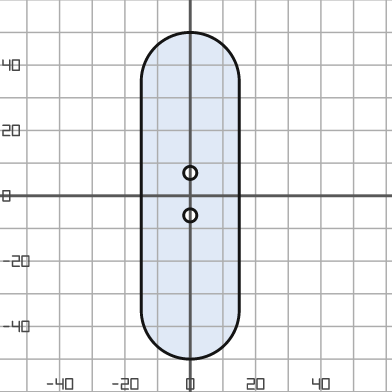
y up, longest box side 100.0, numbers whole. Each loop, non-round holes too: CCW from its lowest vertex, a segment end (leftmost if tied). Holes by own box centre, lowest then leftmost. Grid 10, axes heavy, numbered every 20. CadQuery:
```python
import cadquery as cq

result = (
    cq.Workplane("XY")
    .moveTo(-15.0, -35.0)
    .threePointArc((0.0, -50.0), (15.0, -35.0))
    .lineTo(15.0, 35.0)
    .threePointArc((0.0, 50.0), (-15.0, 35.0))
    .close()
    .moveTo(0.0, -6.0)
    .circle(2.0)
    .moveTo(0.0, 7.0)
    .circle(2.0)
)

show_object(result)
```